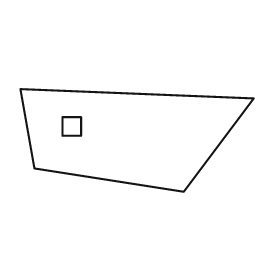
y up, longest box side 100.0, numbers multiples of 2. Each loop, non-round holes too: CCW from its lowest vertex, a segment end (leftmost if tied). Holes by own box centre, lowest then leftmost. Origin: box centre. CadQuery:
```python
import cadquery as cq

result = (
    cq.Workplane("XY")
    .moveTo(20.0, -22.0)
    .lineTo(50.0, 18.0)
    .lineTo(-50.0, 22.0)
    .lineTo(-44.0, -12.0)
    .close()
    .moveTo(-32.0, 2.0)
    .lineTo(-24.0, 2.0)
    .lineTo(-24.0, 10.0)
    .lineTo(-32.0, 10.0)
    .close()
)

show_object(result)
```